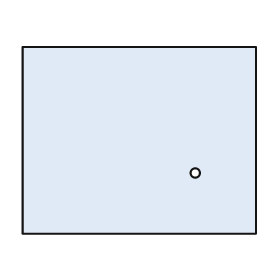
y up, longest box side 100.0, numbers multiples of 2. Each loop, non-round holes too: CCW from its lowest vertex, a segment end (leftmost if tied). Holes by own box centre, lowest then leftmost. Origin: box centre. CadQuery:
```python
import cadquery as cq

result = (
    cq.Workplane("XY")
    .moveTo(-50.0, -40.0)
    .lineTo(50.0, -40.0)
    .lineTo(50.0, 40.0)
    .lineTo(-50.0, 40.0)
    .close()
    .moveTo(24.0, -14.0)
    .circle(2.0)
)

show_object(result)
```